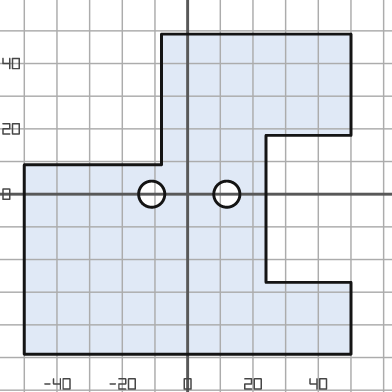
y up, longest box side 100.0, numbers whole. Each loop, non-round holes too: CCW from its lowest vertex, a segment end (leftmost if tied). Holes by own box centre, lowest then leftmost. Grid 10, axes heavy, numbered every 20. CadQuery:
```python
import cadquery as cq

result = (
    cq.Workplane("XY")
    .moveTo(-50.0, -49.0)
    .lineTo(50.0, -49.0)
    .lineTo(50.0, -27.0)
    .lineTo(24.0, -27.0)
    .lineTo(24.0, 18.0)
    .lineTo(50.0, 18.0)
    .lineTo(50.0, 49.0)
    .lineTo(-8.0, 49.0)
    .lineTo(-8.0, 9.0)
    .lineTo(-50.0, 9.0)
    .close()
    .moveTo(-11.0, 0.0)
    .circle(4.0)
    .moveTo(12.0, 0.0)
    .circle(4.0)
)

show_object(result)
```